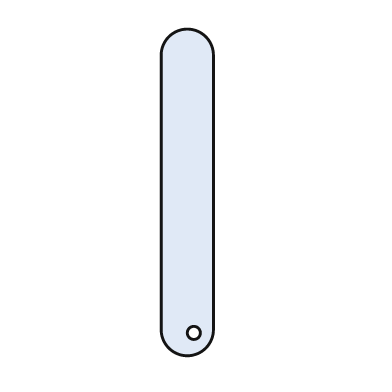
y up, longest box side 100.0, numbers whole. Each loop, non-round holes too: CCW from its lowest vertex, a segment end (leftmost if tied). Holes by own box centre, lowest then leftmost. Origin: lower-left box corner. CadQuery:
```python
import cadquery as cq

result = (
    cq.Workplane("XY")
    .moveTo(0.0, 8.0)
    .threePointArc((8.0, 0.0), (16.0, 8.0))
    .lineTo(16.0, 92.0)
    .threePointArc((8.0, 100.0), (0.0, 92.0))
    .close()
    .moveTo(10.0, 7.0)
    .circle(2.0)
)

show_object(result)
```